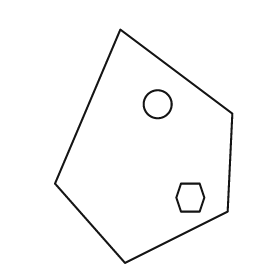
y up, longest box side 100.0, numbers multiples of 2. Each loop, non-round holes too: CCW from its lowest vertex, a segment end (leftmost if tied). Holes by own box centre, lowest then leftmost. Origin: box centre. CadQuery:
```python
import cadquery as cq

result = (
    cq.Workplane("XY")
    .moveTo(-8.0, -50.0)
    .lineTo(36.0, -28.0)
    .lineTo(38.0, 14.0)
    .lineTo(-10.0, 50.0)
    .lineTo(-38.0, -16.0)
    .close()
    .moveTo(16.0, -28.0)
    .lineTo(24.0, -28.0)
    .lineTo(26.0, -22.0)
    .lineTo(24.0, -16.0)
    .lineTo(16.0, -16.0)
    .lineTo(14.0, -22.0)
    .close()
    .moveTo(6.0, 18.0)
    .circle(6.0)
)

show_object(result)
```